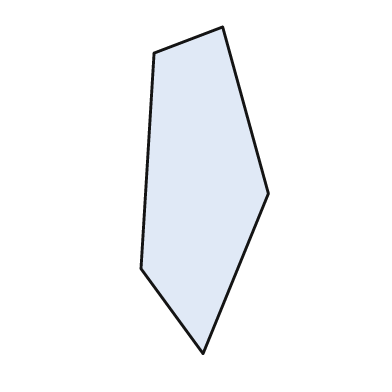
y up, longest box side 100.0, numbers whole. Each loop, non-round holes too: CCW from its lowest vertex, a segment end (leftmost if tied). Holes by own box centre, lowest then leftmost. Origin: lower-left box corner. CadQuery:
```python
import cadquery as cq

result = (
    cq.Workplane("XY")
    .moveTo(19.0, 0.0)
    .lineTo(39.0, 49.0)
    .lineTo(25.0, 100.0)
    .lineTo(4.0, 92.0)
    .lineTo(0.0, 26.0)
    .close()
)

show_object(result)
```